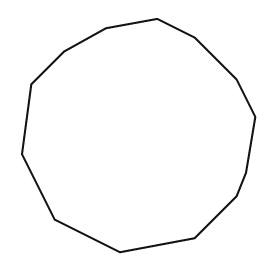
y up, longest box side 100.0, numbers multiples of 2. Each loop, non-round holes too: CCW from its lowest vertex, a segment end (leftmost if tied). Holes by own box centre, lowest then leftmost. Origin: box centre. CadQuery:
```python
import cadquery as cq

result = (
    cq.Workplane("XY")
    .moveTo(-8.0, -50.0)
    .lineTo(24.0, -44.0)
    .lineTo(42.0, -26.0)
    .lineTo(46.0, -16.0)
    .lineTo(50.0, 8.0)
    .lineTo(42.0, 24.0)
    .lineTo(24.0, 42.0)
    .lineTo(8.0, 50.0)
    .lineTo(-14.0, 46.0)
    .lineTo(-32.0, 36.0)
    .lineTo(-46.0, 22.0)
    .lineTo(-50.0, -8.0)
    .lineTo(-36.0, -36.0)
    .close()
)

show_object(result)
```